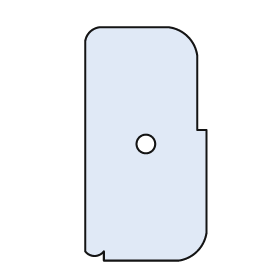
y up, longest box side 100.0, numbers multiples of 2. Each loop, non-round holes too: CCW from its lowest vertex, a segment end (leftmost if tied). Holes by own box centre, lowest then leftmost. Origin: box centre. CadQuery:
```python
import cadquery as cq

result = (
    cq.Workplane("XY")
    .moveTo(-18.0, -50.0)
    .lineTo(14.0, -50.0)
    .threePointArc((22.0, -46.0), (26.0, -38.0))
    .lineTo(26.0, 6.0)
    .lineTo(22.0, 6.0)
    .lineTo(22.0, 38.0)
    .threePointArc((18.0, 46.0), (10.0, 50.0))
    .lineTo(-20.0, 50.0)
    .threePointArc((-24.0, 48.0), (-26.0, 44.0))
    .lineTo(-26.0, -46.0)
    .threePointArc((-22.0, -48.0), (-18.0, -46.0))
    .close()
    .moveTo(0.0, 0.0)
    .circle(4.0)
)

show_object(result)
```